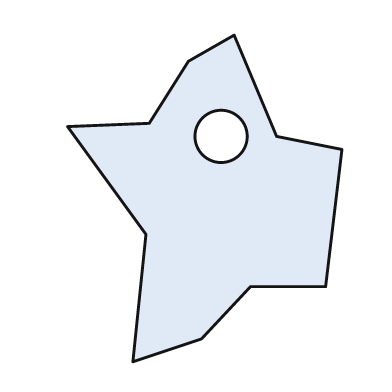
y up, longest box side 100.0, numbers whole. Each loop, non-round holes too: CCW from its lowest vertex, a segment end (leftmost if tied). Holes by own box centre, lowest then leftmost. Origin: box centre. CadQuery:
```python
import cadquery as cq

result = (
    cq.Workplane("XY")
    .moveTo(-22.0, -50.0)
    .lineTo(-1.0, -43.0)
    .lineTo(14.0, -27.0)
    .lineTo(37.0, -27.0)
    .lineTo(42.0, 15.0)
    .lineTo(22.0, 19.0)
    .lineTo(9.0, 50.0)
    .lineTo(-5.0, 42.0)
    .lineTo(-17.0, 23.0)
    .lineTo(-42.0, 22.0)
    .lineTo(-18.0, -11.0)
    .close()
    .moveTo(5.0, 19.0)
    .circle(8.0)
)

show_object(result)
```